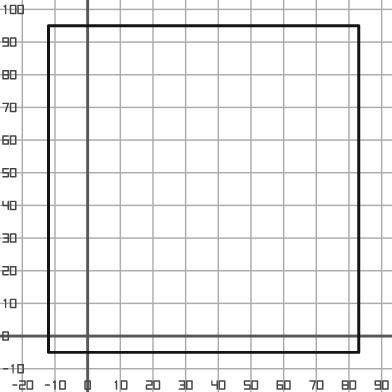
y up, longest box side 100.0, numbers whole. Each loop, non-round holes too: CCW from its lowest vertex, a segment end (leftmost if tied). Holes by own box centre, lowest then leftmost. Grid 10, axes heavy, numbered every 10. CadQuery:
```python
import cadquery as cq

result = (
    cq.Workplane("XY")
    .moveTo(-12.0, -5.0)
    .lineTo(83.0, -5.0)
    .lineTo(83.0, 95.0)
    .lineTo(-12.0, 95.0)
    .close()
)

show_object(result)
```